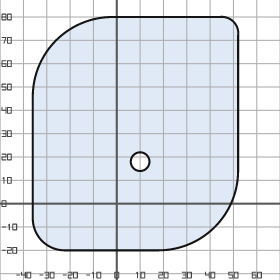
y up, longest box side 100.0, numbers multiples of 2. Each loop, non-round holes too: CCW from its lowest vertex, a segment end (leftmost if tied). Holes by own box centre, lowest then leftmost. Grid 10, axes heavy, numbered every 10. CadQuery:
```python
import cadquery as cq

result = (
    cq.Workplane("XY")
    .moveTo(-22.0, -20.0)
    .lineTo(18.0, -20.0)
    .threePointArc((42.0, -10.0), (52.0, 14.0))
    .lineTo(52.0, 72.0)
    .threePointArc((50.0, 78.0), (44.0, 80.0))
    .lineTo(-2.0, 80.0)
    .threePointArc((-26.0, 70.0), (-36.0, 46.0))
    .lineTo(-36.0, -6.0)
    .threePointArc((-32.0, -16.0), (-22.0, -20.0))
    .close()
    .moveTo(10.0, 18.0)
    .circle(4.0)
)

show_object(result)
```